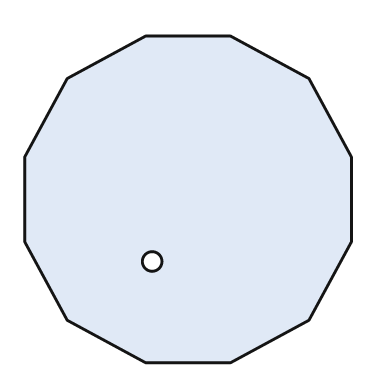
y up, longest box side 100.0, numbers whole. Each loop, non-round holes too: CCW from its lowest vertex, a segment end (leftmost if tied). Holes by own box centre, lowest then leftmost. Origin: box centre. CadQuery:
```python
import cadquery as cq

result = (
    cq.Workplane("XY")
    .moveTo(-13.0, -50.0)
    .lineTo(13.0, -50.0)
    .lineTo(37.0, -37.0)
    .lineTo(50.0, -13.0)
    .lineTo(50.0, 13.0)
    .lineTo(37.0, 37.0)
    .lineTo(13.0, 50.0)
    .lineTo(-13.0, 50.0)
    .lineTo(-37.0, 37.0)
    .lineTo(-50.0, 13.0)
    .lineTo(-50.0, -13.0)
    .lineTo(-37.0, -37.0)
    .close()
    .moveTo(-11.0, -19.0)
    .circle(3.0)
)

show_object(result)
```